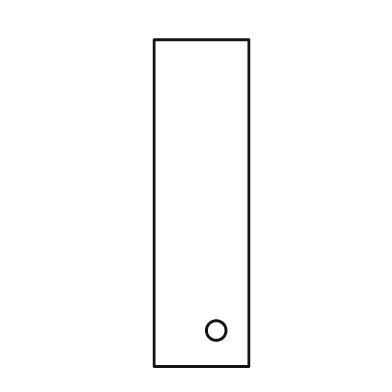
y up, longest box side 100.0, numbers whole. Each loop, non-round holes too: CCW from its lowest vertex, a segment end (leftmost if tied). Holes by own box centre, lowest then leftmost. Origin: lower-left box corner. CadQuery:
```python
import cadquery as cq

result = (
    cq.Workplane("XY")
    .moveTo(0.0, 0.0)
    .lineTo(29.0, 0.0)
    .lineTo(29.0, 100.0)
    .lineTo(0.0, 100.0)
    .close()
    .moveTo(19.0, 11.0)
    .circle(3.0)
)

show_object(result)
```